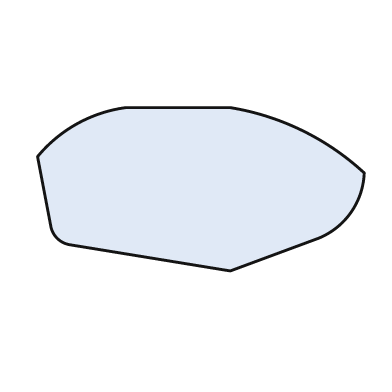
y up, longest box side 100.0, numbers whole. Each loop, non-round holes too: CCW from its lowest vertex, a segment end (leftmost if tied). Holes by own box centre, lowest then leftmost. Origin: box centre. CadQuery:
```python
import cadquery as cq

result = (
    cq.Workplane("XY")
    .moveTo(9.0, -25.0)
    .lineTo(36.0, -15.0)
    .threePointArc((46.0, -7.0), (50.0, 5.0))
    .threePointArc((31.0, 18.0), (9.0, 25.0))
    .lineTo(-23.0, 25.0)
    .threePointArc((-38.0, 20.0), (-50.0, 10.0))
    .lineTo(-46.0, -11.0)
    .threePointArc((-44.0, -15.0), (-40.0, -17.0))
    .close()
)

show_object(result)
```